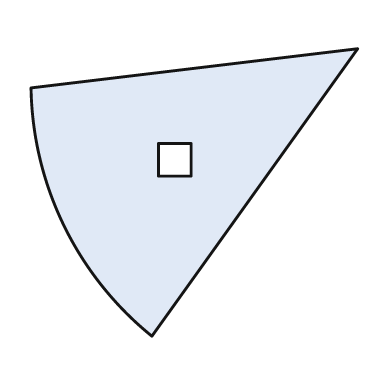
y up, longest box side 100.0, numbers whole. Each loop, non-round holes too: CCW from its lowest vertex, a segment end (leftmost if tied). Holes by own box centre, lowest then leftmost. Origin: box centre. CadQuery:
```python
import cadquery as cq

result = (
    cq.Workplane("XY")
    .moveTo(-13.0, -44.0)
    .lineTo(50.0, 44.0)
    .lineTo(-50.0, 32.0)
    .threePointArc((-40.0, -10.0), (-13.0, -44.0))
    .close()
    .moveTo(-11.0, 5.0)
    .lineTo(-1.0, 5.0)
    .lineTo(-1.0, 15.0)
    .lineTo(-11.0, 15.0)
    .close()
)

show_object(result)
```